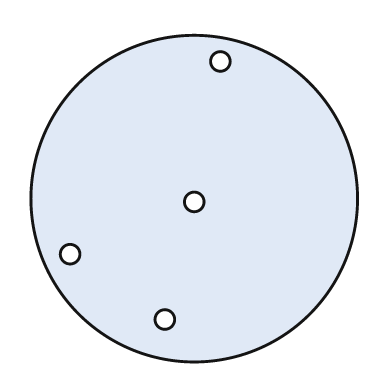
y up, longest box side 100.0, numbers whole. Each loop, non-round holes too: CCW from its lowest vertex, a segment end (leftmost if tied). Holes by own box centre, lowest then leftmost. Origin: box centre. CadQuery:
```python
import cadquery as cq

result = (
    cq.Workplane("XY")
    .moveTo(0.0, 0.0)
    .circle(50.0)
    .moveTo(-9.0, -37.0)
    .circle(3.0)
    .moveTo(-38.0, -17.0)
    .circle(3.0)
    .moveTo(0.0, -1.0)
    .circle(3.0)
    .moveTo(8.0, 42.0)
    .circle(3.0)
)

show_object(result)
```